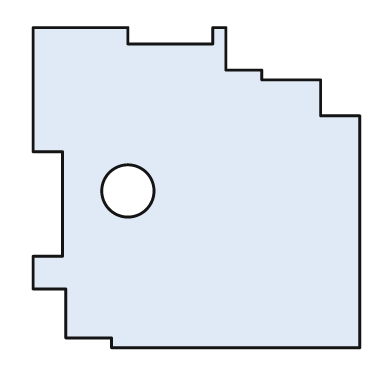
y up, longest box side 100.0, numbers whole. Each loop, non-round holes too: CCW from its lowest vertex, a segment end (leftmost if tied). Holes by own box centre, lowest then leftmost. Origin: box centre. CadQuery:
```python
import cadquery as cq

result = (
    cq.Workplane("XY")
    .moveTo(-26.0, -49.0)
    .lineTo(50.0, -49.0)
    .lineTo(50.0, 22.0)
    .lineTo(38.0, 22.0)
    .lineTo(38.0, 33.0)
    .lineTo(20.0, 33.0)
    .lineTo(20.0, 36.0)
    .lineTo(9.0, 36.0)
    .lineTo(9.0, 49.0)
    .lineTo(5.0, 49.0)
    .lineTo(5.0, 44.0)
    .lineTo(-21.0, 44.0)
    .lineTo(-21.0, 49.0)
    .lineTo(-50.0, 49.0)
    .lineTo(-50.0, 11.0)
    .lineTo(-41.0, 11.0)
    .lineTo(-41.0, -21.0)
    .lineTo(-50.0, -21.0)
    .lineTo(-50.0, -31.0)
    .lineTo(-40.0, -31.0)
    .lineTo(-40.0, -46.0)
    .lineTo(-26.0, -46.0)
    .close()
    .moveTo(-21.0, -1.0)
    .circle(8.0)
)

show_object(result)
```